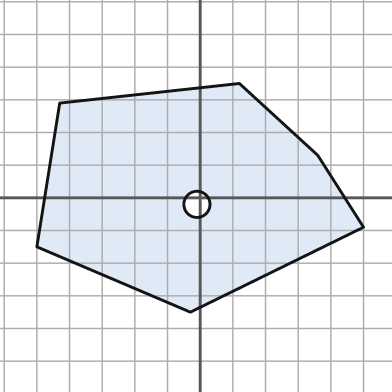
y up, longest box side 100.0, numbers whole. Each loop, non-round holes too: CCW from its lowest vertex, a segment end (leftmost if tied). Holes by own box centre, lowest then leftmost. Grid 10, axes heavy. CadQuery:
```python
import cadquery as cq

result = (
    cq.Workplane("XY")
    .moveTo(-3.0, -35.0)
    .lineTo(50.0, -9.0)
    .lineTo(36.0, 13.0)
    .lineTo(12.0, 35.0)
    .lineTo(-43.0, 29.0)
    .lineTo(-50.0, -15.0)
    .close()
    .moveTo(-1.0, -2.0)
    .circle(4.0)
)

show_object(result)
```